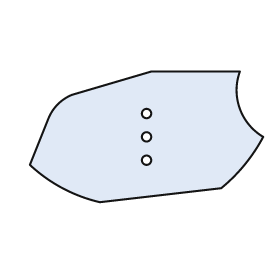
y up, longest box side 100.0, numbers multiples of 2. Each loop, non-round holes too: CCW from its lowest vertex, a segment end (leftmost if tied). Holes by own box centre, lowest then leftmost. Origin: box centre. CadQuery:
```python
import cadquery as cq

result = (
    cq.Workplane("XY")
    .moveTo(-20.0, -28.0)
    .lineTo(32.0, -22.0)
    .threePointArc((42.0, -12.0), (50.0, 0.0))
    .threePointArc((40.0, 12.0), (40.0, 28.0))
    .lineTo(2.0, 28.0)
    .lineTo(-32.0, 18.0)
    .threePointArc((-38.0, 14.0), (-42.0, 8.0))
    .lineTo(-50.0, -12.0)
    .threePointArc((-36.0, -22.0), (-20.0, -28.0))
    .close()
    .moveTo(0.0, -10.0)
    .circle(2.0)
    .moveTo(0.0, 0.0)
    .circle(2.0)
    .moveTo(0.0, 10.0)
    .circle(2.0)
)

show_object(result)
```